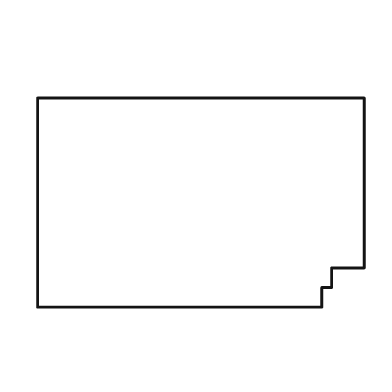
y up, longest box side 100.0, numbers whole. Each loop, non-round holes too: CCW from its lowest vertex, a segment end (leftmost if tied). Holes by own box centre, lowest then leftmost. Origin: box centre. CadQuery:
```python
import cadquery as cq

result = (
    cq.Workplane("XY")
    .moveTo(-50.0, -32.0)
    .lineTo(37.0, -32.0)
    .lineTo(37.0, -26.0)
    .lineTo(40.0, -26.0)
    .lineTo(40.0, -20.0)
    .lineTo(50.0, -20.0)
    .lineTo(50.0, 32.0)
    .lineTo(-50.0, 32.0)
    .close()
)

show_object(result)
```